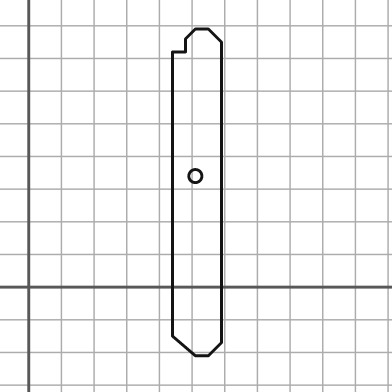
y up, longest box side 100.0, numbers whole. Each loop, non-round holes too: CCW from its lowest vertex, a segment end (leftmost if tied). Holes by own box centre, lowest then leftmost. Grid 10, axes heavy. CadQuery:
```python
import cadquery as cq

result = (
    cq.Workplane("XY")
    .moveTo(51.0, -21.0)
    .lineTo(55.0, -21.0)
    .lineTo(59.0, -17.0)
    .lineTo(59.0, 75.0)
    .lineTo(55.0, 79.0)
    .lineTo(51.0, 79.0)
    .lineTo(48.0, 76.0)
    .lineTo(48.0, 72.0)
    .lineTo(44.0, 72.0)
    .lineTo(44.0, -15.0)
    .close()
    .moveTo(51.0, 34.0)
    .circle(2.0)
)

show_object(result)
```